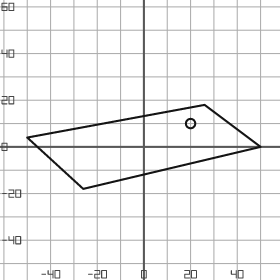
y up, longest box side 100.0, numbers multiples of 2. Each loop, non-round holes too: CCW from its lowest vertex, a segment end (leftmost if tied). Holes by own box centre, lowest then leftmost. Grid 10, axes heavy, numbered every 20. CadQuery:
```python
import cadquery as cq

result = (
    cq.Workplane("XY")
    .moveTo(-26.0, -18.0)
    .lineTo(50.0, 0.0)
    .lineTo(26.0, 18.0)
    .lineTo(-50.0, 4.0)
    .close()
    .moveTo(20.0, 10.0)
    .circle(2.0)
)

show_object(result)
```